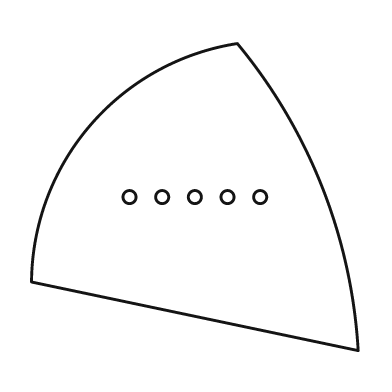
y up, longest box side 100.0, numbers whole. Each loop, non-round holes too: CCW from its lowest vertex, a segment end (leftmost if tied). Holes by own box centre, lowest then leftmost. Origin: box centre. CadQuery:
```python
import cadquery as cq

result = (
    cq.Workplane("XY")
    .moveTo(50.0, -47.0)
    .threePointArc((39.0, 3.0), (13.0, 47.0))
    .threePointArc((-32.0, 22.0), (-50.0, -26.0))
    .close()
    .moveTo(-20.0, 0.0)
    .circle(2.0)
    .moveTo(-10.0, 0.0)
    .circle(2.0)
    .moveTo(0.0, 0.0)
    .circle(2.0)
    .moveTo(10.0, 0.0)
    .circle(2.0)
    .moveTo(20.0, 0.0)
    .circle(2.0)
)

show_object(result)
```